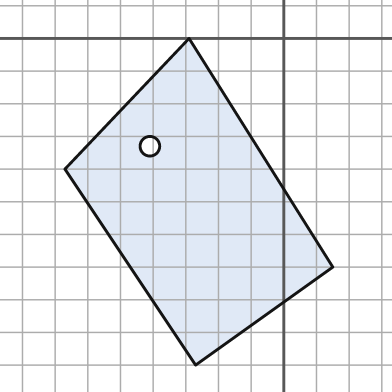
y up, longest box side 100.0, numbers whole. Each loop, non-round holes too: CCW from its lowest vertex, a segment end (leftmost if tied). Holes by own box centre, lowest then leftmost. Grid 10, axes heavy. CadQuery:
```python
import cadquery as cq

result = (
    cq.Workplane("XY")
    .moveTo(-27.0, -100.0)
    .lineTo(15.0, -70.0)
    .lineTo(-29.0, 0.0)
    .lineTo(-67.0, -40.0)
    .close()
    .moveTo(-41.0, -33.0)
    .circle(3.0)
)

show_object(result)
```